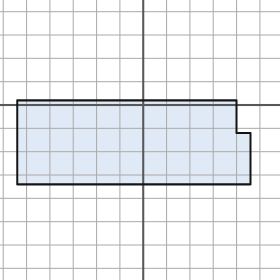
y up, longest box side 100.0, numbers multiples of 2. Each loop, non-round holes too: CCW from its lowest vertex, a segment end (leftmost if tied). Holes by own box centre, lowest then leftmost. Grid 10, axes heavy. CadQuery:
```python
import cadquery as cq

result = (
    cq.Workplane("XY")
    .moveTo(-54.0, -34.0)
    .lineTo(46.0, -34.0)
    .lineTo(46.0, -12.0)
    .lineTo(40.0, -12.0)
    .lineTo(40.0, 2.0)
    .lineTo(-54.0, 2.0)
    .close()
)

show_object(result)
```